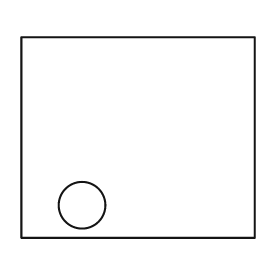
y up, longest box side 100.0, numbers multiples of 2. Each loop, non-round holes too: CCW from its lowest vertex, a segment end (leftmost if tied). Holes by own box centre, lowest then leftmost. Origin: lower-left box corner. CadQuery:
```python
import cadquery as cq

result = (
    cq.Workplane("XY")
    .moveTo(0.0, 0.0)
    .lineTo(100.0, 0.0)
    .lineTo(100.0, 86.0)
    .lineTo(0.0, 86.0)
    .close()
    .moveTo(26.0, 14.0)
    .circle(10.0)
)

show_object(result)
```